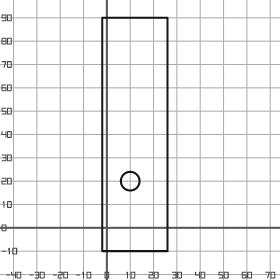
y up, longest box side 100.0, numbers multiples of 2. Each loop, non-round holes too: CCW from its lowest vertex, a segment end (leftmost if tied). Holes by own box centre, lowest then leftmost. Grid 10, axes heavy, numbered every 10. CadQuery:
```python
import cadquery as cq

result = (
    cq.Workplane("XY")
    .moveTo(-2.0, -10.0)
    .lineTo(26.0, -10.0)
    .lineTo(26.0, 90.0)
    .lineTo(-2.0, 90.0)
    .close()
    .moveTo(10.0, 20.0)
    .circle(4.0)
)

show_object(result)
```